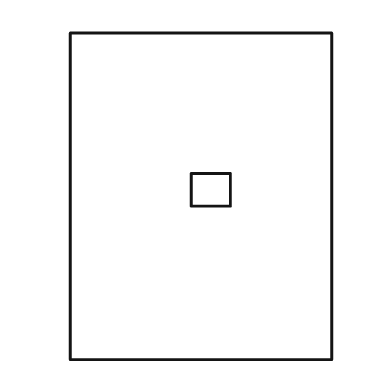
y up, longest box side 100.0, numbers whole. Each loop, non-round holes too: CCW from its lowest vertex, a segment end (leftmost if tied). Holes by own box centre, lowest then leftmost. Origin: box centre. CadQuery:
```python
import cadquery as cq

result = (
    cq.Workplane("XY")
    .moveTo(-40.0, -50.0)
    .lineTo(40.0, -50.0)
    .lineTo(40.0, 50.0)
    .lineTo(-40.0, 50.0)
    .close()
    .moveTo(-3.0, -3.0)
    .lineTo(9.0, -3.0)
    .lineTo(9.0, 7.0)
    .lineTo(-3.0, 7.0)
    .close()
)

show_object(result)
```